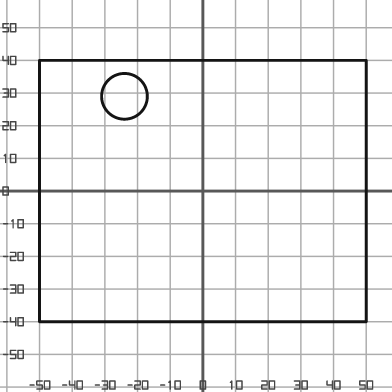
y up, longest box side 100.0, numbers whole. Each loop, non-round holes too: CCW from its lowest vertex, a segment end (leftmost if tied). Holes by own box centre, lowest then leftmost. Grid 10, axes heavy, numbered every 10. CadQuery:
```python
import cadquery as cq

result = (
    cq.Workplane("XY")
    .moveTo(-50.0, -40.0)
    .lineTo(50.0, -40.0)
    .lineTo(50.0, 40.0)
    .lineTo(-50.0, 40.0)
    .close()
    .moveTo(-24.0, 29.0)
    .circle(7.0)
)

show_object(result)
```